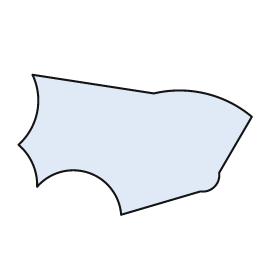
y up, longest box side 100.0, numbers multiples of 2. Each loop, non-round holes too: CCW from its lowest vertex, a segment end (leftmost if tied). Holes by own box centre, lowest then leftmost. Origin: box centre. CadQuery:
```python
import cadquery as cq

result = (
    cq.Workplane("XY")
    .moveTo(-6.0, -30.0)
    .lineTo(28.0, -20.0)
    .threePointArc((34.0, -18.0), (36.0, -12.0))
    .lineTo(50.0, 12.0)
    .threePointArc((30.0, 22.0), (8.0, 22.0))
    .lineTo(-44.0, 30.0)
    .threePointArc((-42.0, 14.0), (-50.0, 0.0))
    .threePointArc((-44.0, -8.0), (-42.0, -18.0))
    .threePointArc((-20.0, -12.0), (-6.0, -30.0))
    .close()
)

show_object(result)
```